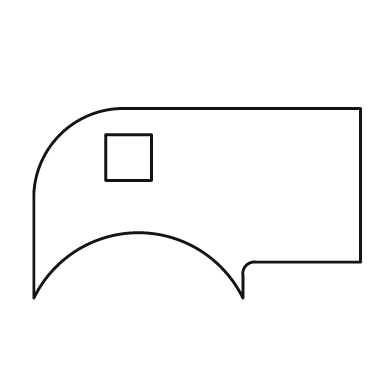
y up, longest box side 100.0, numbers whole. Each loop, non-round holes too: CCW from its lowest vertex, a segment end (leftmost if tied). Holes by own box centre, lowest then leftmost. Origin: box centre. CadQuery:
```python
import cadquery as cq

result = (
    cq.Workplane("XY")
    .moveTo(-50.0, -29.0)
    .threePointArc((-18.0, -9.0), (14.0, -29.0))
    .lineTo(14.0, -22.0)
    .threePointArc((15.0, -19.0), (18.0, -18.0))
    .lineTo(50.0, -18.0)
    .lineTo(50.0, 29.0)
    .lineTo(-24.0, 29.0)
    .threePointArc((-42.0, 21.0), (-50.0, 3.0))
    .close()
    .moveTo(-28.0, 7.0)
    .lineTo(-14.0, 7.0)
    .lineTo(-14.0, 21.0)
    .lineTo(-28.0, 21.0)
    .close()
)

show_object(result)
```